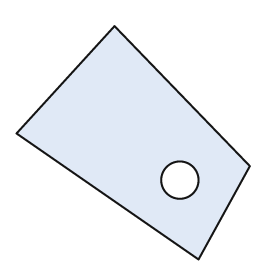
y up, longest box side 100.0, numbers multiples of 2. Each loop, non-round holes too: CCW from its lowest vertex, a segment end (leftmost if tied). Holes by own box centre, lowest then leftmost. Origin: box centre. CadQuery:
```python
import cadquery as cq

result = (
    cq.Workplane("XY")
    .moveTo(28.0, -50.0)
    .lineTo(50.0, -10.0)
    .lineTo(-8.0, 50.0)
    .lineTo(-50.0, 4.0)
    .close()
    .moveTo(20.0, -16.0)
    .circle(8.0)
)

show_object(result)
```